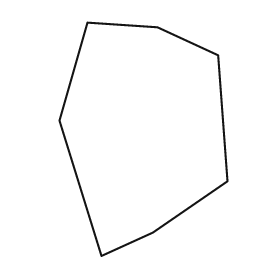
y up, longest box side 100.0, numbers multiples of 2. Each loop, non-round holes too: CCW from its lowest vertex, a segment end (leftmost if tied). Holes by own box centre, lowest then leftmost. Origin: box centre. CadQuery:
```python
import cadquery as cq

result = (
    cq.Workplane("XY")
    .moveTo(-18.0, -50.0)
    .lineTo(4.0, -40.0)
    .lineTo(36.0, -18.0)
    .lineTo(32.0, 36.0)
    .lineTo(6.0, 48.0)
    .lineTo(-24.0, 50.0)
    .lineTo(-36.0, 8.0)
    .close()
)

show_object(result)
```